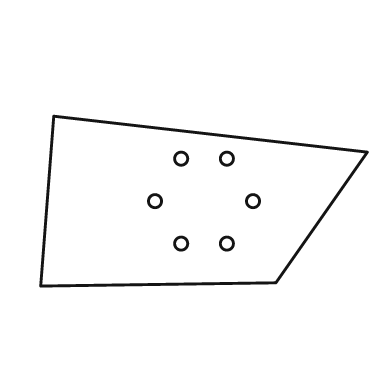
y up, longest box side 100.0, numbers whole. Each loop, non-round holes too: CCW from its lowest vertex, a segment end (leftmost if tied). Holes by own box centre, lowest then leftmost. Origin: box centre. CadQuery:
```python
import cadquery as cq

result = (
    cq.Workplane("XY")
    .moveTo(-50.0, -26.0)
    .lineTo(22.0, -25.0)
    .lineTo(50.0, 15.0)
    .lineTo(-46.0, 26.0)
    .close()
    .moveTo(-7.0, -13.0)
    .circle(2.0)
    .moveTo(7.0, -13.0)
    .circle(2.0)
    .moveTo(-15.0, 0.0)
    .circle(2.0)
    .moveTo(15.0, 0.0)
    .circle(2.0)
    .moveTo(-7.0, 13.0)
    .circle(2.0)
    .moveTo(7.0, 13.0)
    .circle(2.0)
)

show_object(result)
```